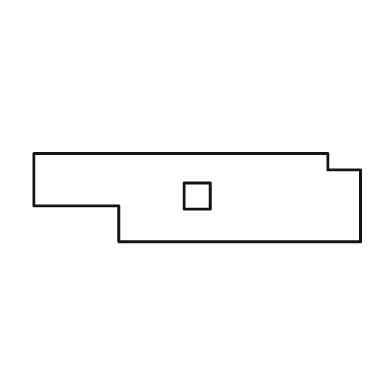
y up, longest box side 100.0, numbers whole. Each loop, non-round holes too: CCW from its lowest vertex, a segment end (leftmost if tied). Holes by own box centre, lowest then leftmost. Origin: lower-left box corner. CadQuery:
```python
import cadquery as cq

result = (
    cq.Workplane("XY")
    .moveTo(26.0, 0.0)
    .lineTo(100.0, 0.0)
    .lineTo(100.0, 22.0)
    .lineTo(90.0, 22.0)
    .lineTo(90.0, 27.0)
    .lineTo(0.0, 27.0)
    .lineTo(0.0, 11.0)
    .lineTo(26.0, 11.0)
    .close()
    .moveTo(46.0, 10.0)
    .lineTo(54.0, 10.0)
    .lineTo(54.0, 18.0)
    .lineTo(46.0, 18.0)
    .close()
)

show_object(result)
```